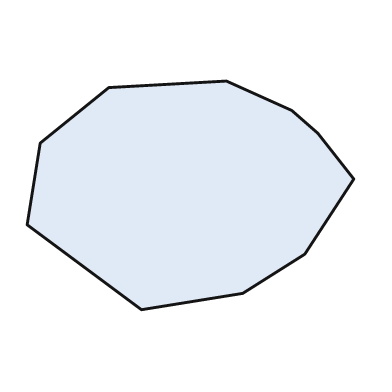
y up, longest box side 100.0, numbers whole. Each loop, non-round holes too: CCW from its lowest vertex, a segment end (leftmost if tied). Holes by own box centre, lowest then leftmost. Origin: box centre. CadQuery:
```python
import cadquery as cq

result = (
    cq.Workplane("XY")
    .moveTo(-15.0, -35.0)
    .lineTo(16.0, -30.0)
    .lineTo(35.0, -18.0)
    .lineTo(50.0, 5.0)
    .lineTo(39.0, 19.0)
    .lineTo(31.0, 26.0)
    .lineTo(11.0, 35.0)
    .lineTo(-25.0, 33.0)
    .lineTo(-46.0, 16.0)
    .lineTo(-50.0, -9.0)
    .close()
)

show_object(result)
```